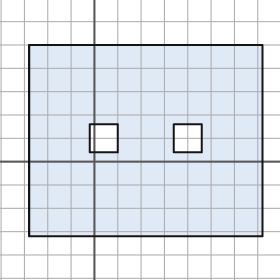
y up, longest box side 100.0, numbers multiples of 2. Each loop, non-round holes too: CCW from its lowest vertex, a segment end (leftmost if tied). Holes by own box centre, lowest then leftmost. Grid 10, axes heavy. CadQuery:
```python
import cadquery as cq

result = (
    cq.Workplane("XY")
    .moveTo(-28.0, -32.0)
    .lineTo(72.0, -32.0)
    .lineTo(72.0, 50.0)
    .lineTo(-28.0, 50.0)
    .close()
    .moveTo(-2.0, 4.0)
    .lineTo(10.0, 4.0)
    .lineTo(10.0, 16.0)
    .lineTo(-2.0, 16.0)
    .close()
    .moveTo(34.0, 4.0)
    .lineTo(46.0, 4.0)
    .lineTo(46.0, 16.0)
    .lineTo(34.0, 16.0)
    .close()
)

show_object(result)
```